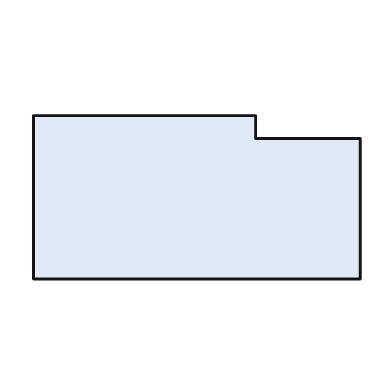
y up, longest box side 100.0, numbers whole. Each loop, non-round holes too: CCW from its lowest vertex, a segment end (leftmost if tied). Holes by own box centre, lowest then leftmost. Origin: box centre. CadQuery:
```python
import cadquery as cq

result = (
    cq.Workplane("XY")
    .moveTo(-50.0, -25.0)
    .lineTo(50.0, -25.0)
    .lineTo(50.0, 18.0)
    .lineTo(18.0, 18.0)
    .lineTo(18.0, 25.0)
    .lineTo(-50.0, 25.0)
    .close()
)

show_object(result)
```